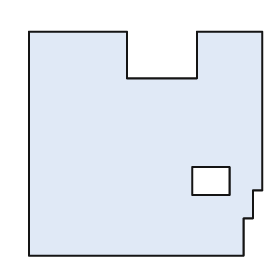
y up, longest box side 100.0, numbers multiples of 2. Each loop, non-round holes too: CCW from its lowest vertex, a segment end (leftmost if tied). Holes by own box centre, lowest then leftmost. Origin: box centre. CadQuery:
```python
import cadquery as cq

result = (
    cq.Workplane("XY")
    .moveTo(-50.0, -48.0)
    .lineTo(42.0, -48.0)
    .lineTo(42.0, -32.0)
    .lineTo(46.0, -32.0)
    .lineTo(46.0, -20.0)
    .lineTo(50.0, -20.0)
    .lineTo(50.0, 48.0)
    .lineTo(22.0, 48.0)
    .lineTo(22.0, 28.0)
    .lineTo(-8.0, 28.0)
    .lineTo(-8.0, 48.0)
    .lineTo(-50.0, 48.0)
    .close()
    .moveTo(20.0, -22.0)
    .lineTo(36.0, -22.0)
    .lineTo(36.0, -10.0)
    .lineTo(20.0, -10.0)
    .close()
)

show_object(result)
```